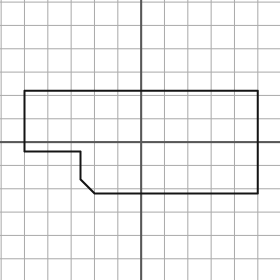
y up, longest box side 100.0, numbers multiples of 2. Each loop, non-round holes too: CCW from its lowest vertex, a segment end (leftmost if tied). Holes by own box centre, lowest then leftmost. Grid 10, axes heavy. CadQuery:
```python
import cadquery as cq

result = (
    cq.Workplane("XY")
    .moveTo(-20.0, -22.0)
    .lineTo(50.0, -22.0)
    .lineTo(50.0, 22.0)
    .lineTo(-50.0, 22.0)
    .lineTo(-50.0, -4.0)
    .lineTo(-26.0, -4.0)
    .lineTo(-26.0, -16.0)
    .close()
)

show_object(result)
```